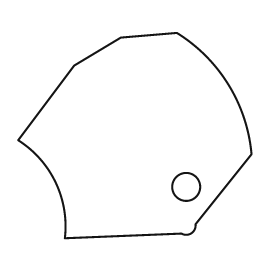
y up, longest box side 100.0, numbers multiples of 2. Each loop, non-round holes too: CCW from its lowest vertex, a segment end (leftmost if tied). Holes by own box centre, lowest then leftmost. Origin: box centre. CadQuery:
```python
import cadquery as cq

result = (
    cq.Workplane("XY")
    .moveTo(-30.0, -44.0)
    .lineTo(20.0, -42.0)
    .threePointArc((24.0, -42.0), (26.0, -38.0))
    .lineTo(50.0, -8.0)
    .threePointArc((40.0, 22.0), (18.0, 44.0))
    .lineTo(-6.0, 42.0)
    .lineTo(-26.0, 30.0)
    .lineTo(-50.0, -2.0)
    .threePointArc((-34.0, -20.0), (-30.0, -44.0))
    .close()
    .moveTo(22.0, -22.0)
    .circle(6.0)
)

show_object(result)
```